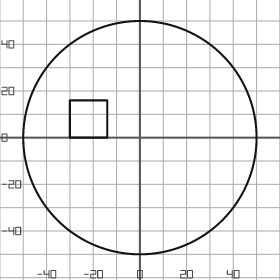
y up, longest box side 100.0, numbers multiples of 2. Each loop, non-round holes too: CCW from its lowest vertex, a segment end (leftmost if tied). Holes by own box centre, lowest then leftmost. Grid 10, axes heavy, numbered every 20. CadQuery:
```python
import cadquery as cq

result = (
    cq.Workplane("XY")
    .moveTo(0.0, 0.0)
    .circle(50.0)
    .moveTo(-30.0, 0.0)
    .lineTo(-14.0, 0.0)
    .lineTo(-14.0, 16.0)
    .lineTo(-30.0, 16.0)
    .close()
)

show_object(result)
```